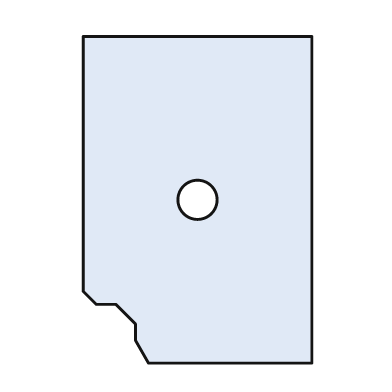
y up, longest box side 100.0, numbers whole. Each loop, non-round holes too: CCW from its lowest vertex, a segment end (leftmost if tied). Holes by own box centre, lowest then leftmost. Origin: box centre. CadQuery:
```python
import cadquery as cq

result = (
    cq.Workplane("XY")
    .moveTo(-15.0, -50.0)
    .lineTo(35.0, -50.0)
    .lineTo(35.0, 50.0)
    .lineTo(-35.0, 50.0)
    .lineTo(-35.0, -28.0)
    .lineTo(-31.0, -32.0)
    .lineTo(-25.0, -32.0)
    .lineTo(-19.0, -38.0)
    .lineTo(-19.0, -43.0)
    .close()
    .moveTo(0.0, 0.0)
    .circle(6.0)
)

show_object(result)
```